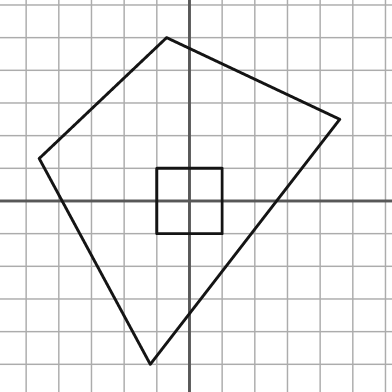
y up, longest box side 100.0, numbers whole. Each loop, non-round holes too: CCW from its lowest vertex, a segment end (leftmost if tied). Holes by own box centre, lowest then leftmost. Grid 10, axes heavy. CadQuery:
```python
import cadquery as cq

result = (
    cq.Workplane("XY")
    .moveTo(-12.0, -50.0)
    .lineTo(46.0, 25.0)
    .lineTo(-7.0, 50.0)
    .lineTo(-46.0, 13.0)
    .close()
    .moveTo(-10.0, -10.0)
    .lineTo(10.0, -10.0)
    .lineTo(10.0, 10.0)
    .lineTo(-10.0, 10.0)
    .close()
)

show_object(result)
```